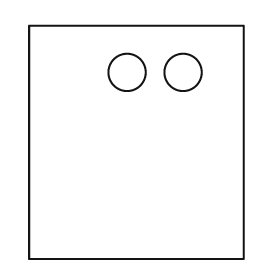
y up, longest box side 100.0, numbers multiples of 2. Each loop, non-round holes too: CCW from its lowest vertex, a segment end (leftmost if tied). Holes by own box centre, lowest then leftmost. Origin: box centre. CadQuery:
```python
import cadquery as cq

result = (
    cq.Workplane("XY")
    .moveTo(-46.0, -50.0)
    .lineTo(46.0, -50.0)
    .lineTo(46.0, 50.0)
    .lineTo(-46.0, 50.0)
    .close()
    .moveTo(-4.0, 30.0)
    .circle(8.0)
    .moveTo(20.0, 30.0)
    .circle(8.0)
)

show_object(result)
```